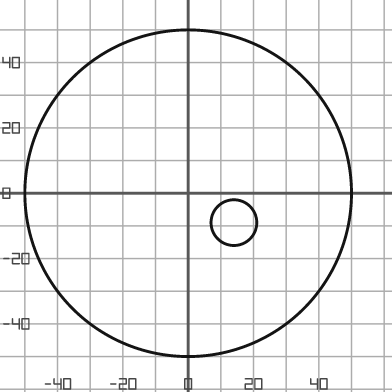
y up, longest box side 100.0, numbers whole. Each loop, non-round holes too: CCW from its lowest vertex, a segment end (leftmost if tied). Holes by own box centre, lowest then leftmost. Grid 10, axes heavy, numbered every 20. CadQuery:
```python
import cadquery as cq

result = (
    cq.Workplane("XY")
    .moveTo(0.0, 0.0)
    .circle(50.0)
    .moveTo(14.0, -9.0)
    .circle(7.0)
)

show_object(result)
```